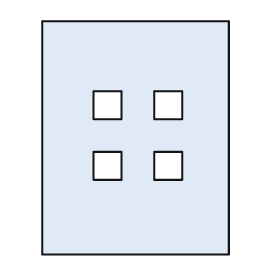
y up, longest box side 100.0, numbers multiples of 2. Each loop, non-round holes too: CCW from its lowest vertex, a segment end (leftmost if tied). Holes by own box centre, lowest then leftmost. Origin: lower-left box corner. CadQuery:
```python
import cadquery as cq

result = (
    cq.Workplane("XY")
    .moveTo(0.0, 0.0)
    .lineTo(80.0, 0.0)
    .lineTo(80.0, 100.0)
    .lineTo(0.0, 100.0)
    .close()
    .moveTo(22.0, 32.0)
    .lineTo(34.0, 32.0)
    .lineTo(34.0, 44.0)
    .lineTo(22.0, 44.0)
    .close()
    .moveTo(48.0, 32.0)
    .lineTo(60.0, 32.0)
    .lineTo(60.0, 44.0)
    .lineTo(48.0, 44.0)
    .close()
    .moveTo(22.0, 58.0)
    .lineTo(34.0, 58.0)
    .lineTo(34.0, 70.0)
    .lineTo(22.0, 70.0)
    .close()
    .moveTo(48.0, 58.0)
    .lineTo(60.0, 58.0)
    .lineTo(60.0, 70.0)
    .lineTo(48.0, 70.0)
    .close()
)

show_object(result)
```